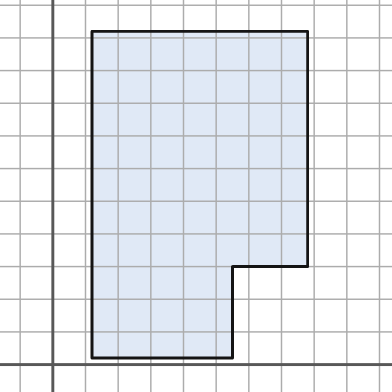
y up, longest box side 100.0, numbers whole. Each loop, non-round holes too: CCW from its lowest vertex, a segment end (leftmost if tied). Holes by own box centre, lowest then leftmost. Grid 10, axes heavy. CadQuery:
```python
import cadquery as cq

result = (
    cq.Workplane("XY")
    .moveTo(12.0, 2.0)
    .lineTo(55.0, 2.0)
    .lineTo(55.0, 30.0)
    .lineTo(78.0, 30.0)
    .lineTo(78.0, 102.0)
    .lineTo(12.0, 102.0)
    .close()
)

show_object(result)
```